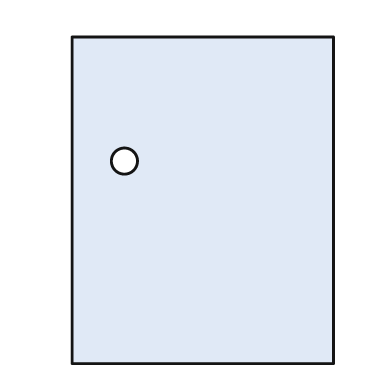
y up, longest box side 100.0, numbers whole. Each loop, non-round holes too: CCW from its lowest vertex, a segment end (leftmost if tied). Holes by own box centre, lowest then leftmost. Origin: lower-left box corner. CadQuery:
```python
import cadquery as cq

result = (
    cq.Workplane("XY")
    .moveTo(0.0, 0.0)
    .lineTo(80.0, 0.0)
    .lineTo(80.0, 100.0)
    .lineTo(0.0, 100.0)
    .close()
    .moveTo(16.0, 62.0)
    .circle(4.0)
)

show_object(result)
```